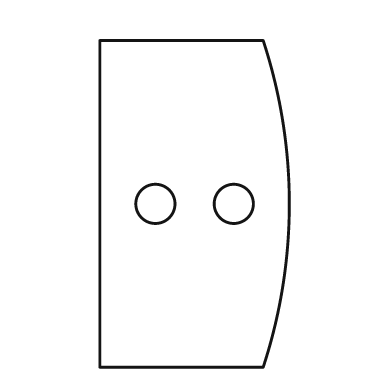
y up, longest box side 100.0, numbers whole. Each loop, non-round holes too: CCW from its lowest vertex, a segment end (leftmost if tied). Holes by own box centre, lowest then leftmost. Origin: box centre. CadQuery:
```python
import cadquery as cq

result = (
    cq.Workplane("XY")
    .moveTo(-29.0, -50.0)
    .lineTo(21.0, -50.0)
    .threePointArc((29.0, 0.0), (21.0, 50.0))
    .lineTo(-29.0, 50.0)
    .close()
    .moveTo(-12.0, 0.0)
    .circle(6.0)
    .moveTo(12.0, 0.0)
    .circle(6.0)
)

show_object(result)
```